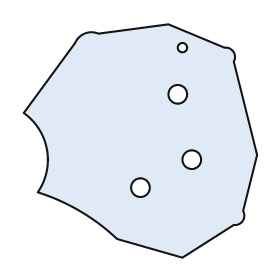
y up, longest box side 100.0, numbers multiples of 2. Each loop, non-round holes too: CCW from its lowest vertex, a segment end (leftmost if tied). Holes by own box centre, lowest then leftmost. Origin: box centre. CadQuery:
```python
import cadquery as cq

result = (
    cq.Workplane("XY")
    .moveTo(18.0, -50.0)
    .lineTo(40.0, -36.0)
    .threePointArc((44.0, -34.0), (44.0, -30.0))
    .lineTo(50.0, -6.0)
    .lineTo(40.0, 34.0)
    .threePointArc((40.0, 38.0), (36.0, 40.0))
    .lineTo(12.0, 50.0)
    .lineTo(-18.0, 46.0)
    .threePointArc((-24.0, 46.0), (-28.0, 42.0))
    .lineTo(-50.0, 12.0)
    .threePointArc((-40.0, -4.0), (-44.0, -22.0))
    .threePointArc((-26.0, -30.0), (-10.0, -42.0))
    .close()
    .moveTo(0.0, -20.0)
    .circle(4.0)
    .moveTo(22.0, -8.0)
    .circle(4.0)
    .moveTo(16.0, 20.0)
    .circle(4.0)
    .moveTo(18.0, 40.0)
    .circle(2.0)
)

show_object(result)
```